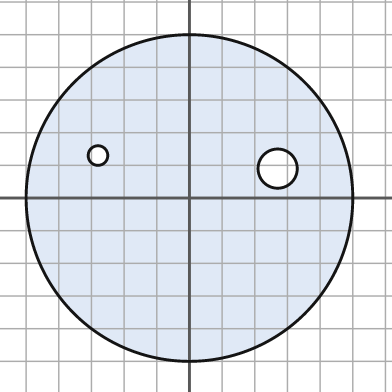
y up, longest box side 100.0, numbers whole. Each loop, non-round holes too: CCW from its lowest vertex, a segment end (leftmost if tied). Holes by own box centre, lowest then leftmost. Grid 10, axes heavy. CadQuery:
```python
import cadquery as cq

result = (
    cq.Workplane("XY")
    .moveTo(0.0, 0.0)
    .circle(50.0)
    .moveTo(27.0, 9.0)
    .circle(6.0)
    .moveTo(-28.0, 13.0)
    .circle(3.0)
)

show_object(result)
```